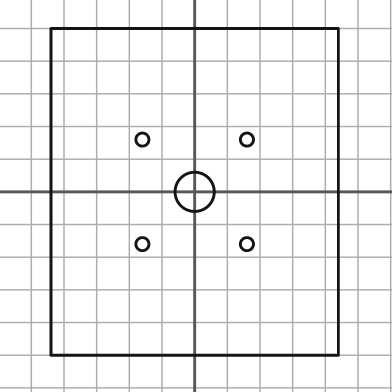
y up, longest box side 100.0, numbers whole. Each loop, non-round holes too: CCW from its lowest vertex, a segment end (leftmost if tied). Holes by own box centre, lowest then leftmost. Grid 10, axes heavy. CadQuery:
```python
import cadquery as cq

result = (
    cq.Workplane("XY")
    .moveTo(-44.0, -50.0)
    .lineTo(44.0, -50.0)
    .lineTo(44.0, 50.0)
    .lineTo(-44.0, 50.0)
    .close()
    .moveTo(-16.0, -16.0)
    .circle(2.0)
    .moveTo(16.0, -16.0)
    .circle(2.0)
    .moveTo(0.0, 0.0)
    .circle(6.0)
    .moveTo(-16.0, 16.0)
    .circle(2.0)
    .moveTo(16.0, 16.0)
    .circle(2.0)
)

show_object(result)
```